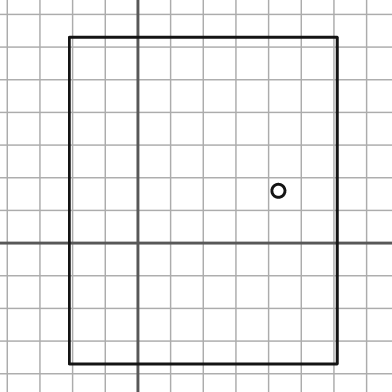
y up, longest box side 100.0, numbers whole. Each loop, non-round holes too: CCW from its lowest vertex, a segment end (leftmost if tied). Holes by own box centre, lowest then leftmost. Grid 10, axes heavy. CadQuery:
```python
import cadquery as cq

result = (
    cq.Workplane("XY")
    .moveTo(-21.0, -37.0)
    .lineTo(61.0, -37.0)
    .lineTo(61.0, 63.0)
    .lineTo(-21.0, 63.0)
    .close()
    .moveTo(43.0, 16.0)
    .circle(2.0)
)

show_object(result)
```